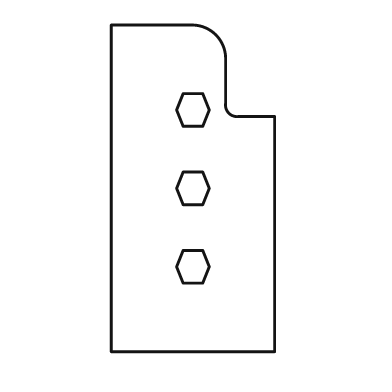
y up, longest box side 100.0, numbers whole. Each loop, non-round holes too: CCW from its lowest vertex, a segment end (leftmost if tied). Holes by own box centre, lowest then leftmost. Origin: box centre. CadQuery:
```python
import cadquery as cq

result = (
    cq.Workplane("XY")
    .moveTo(-25.0, -50.0)
    .lineTo(25.0, -50.0)
    .lineTo(25.0, 22.0)
    .lineTo(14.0, 22.0)
    .threePointArc((11.0, 23.0), (10.0, 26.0))
    .lineTo(10.0, 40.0)
    .threePointArc((7.0, 47.0), (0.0, 50.0))
    .lineTo(-25.0, 50.0)
    .close()
    .moveTo(-3.0, -29.0)
    .lineTo(3.0, -29.0)
    .lineTo(5.0, -24.0)
    .lineTo(3.0, -19.0)
    .lineTo(-3.0, -19.0)
    .lineTo(-5.0, -24.0)
    .close()
    .moveTo(-3.0, -5.0)
    .lineTo(3.0, -5.0)
    .lineTo(5.0, 0.0)
    .lineTo(3.0, 5.0)
    .lineTo(-3.0, 5.0)
    .lineTo(-5.0, 0.0)
    .close()
    .moveTo(-3.0, 19.0)
    .lineTo(3.0, 19.0)
    .lineTo(5.0, 24.0)
    .lineTo(3.0, 29.0)
    .lineTo(-3.0, 29.0)
    .lineTo(-5.0, 24.0)
    .close()
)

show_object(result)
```